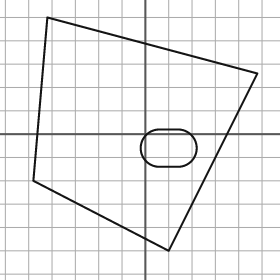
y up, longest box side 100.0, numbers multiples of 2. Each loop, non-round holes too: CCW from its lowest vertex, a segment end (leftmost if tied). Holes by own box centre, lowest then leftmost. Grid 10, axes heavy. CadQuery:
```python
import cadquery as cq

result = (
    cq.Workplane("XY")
    .moveTo(10.0, -50.0)
    .lineTo(48.0, 26.0)
    .lineTo(-42.0, 50.0)
    .lineTo(-48.0, -20.0)
    .close()
    .moveTo(6.0, -14.0)
    .lineTo(14.0, -14.0)
    .threePointArc((22.0, -6.0), (14.0, 2.0))
    .lineTo(6.0, 2.0)
    .threePointArc((-2.0, -6.0), (6.0, -14.0))
    .close()
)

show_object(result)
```